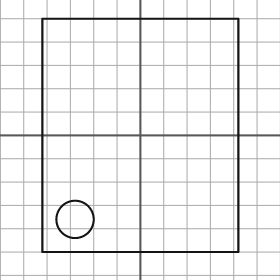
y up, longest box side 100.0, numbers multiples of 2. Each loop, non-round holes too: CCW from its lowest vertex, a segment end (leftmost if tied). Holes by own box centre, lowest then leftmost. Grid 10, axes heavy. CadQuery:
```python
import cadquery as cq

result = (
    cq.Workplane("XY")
    .moveTo(-42.0, -50.0)
    .lineTo(42.0, -50.0)
    .lineTo(42.0, 50.0)
    .lineTo(-42.0, 50.0)
    .close()
    .moveTo(-28.0, -36.0)
    .circle(8.0)
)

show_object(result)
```